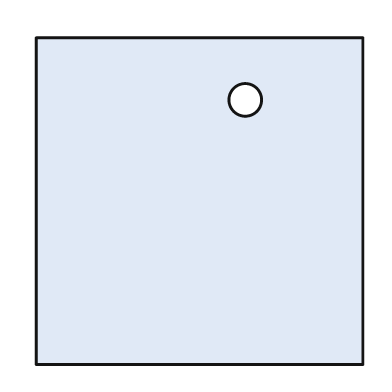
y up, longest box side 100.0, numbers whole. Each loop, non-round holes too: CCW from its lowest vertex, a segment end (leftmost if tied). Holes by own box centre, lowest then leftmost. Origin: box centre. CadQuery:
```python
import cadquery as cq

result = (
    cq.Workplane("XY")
    .moveTo(-50.0, -50.0)
    .lineTo(50.0, -50.0)
    .lineTo(50.0, 50.0)
    .lineTo(-50.0, 50.0)
    .close()
    .moveTo(14.0, 31.0)
    .circle(5.0)
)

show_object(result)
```